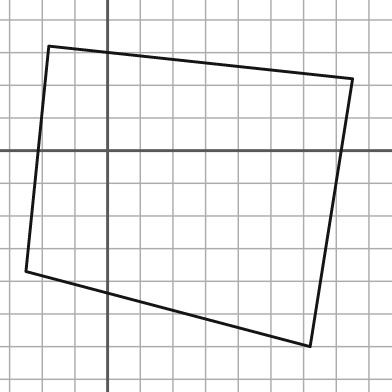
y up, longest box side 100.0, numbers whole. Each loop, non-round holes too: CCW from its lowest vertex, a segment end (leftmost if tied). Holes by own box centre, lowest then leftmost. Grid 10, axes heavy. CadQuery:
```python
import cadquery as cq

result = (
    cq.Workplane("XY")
    .moveTo(62.0, -60.0)
    .lineTo(75.0, 22.0)
    .lineTo(-18.0, 32.0)
    .lineTo(-25.0, -37.0)
    .close()
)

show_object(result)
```